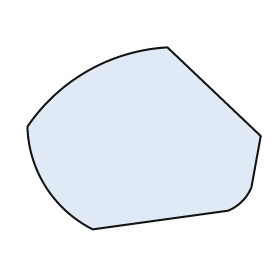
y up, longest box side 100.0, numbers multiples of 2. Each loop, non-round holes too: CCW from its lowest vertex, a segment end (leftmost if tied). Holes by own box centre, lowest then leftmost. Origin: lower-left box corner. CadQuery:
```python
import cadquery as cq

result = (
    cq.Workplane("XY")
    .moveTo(28.0, 0.0)
    .lineTo(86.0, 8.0)
    .threePointArc((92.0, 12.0), (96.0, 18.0))
    .lineTo(100.0, 40.0)
    .lineTo(60.0, 78.0)
    .threePointArc((26.0, 68.0), (0.0, 44.0))
    .threePointArc((8.0, 18.0), (28.0, 0.0))
    .close()
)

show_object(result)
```